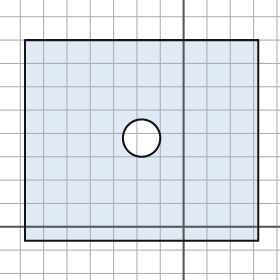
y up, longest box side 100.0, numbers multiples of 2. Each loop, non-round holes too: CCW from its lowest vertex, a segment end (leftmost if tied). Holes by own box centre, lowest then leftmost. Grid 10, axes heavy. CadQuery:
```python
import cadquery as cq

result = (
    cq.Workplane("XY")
    .moveTo(-68.0, -6.0)
    .lineTo(32.0, -6.0)
    .lineTo(32.0, 80.0)
    .lineTo(-68.0, 80.0)
    .close()
    .moveTo(-18.0, 38.0)
    .circle(8.0)
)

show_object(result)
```